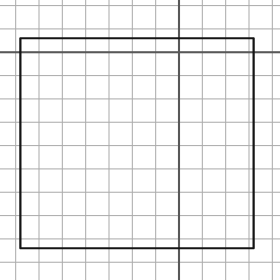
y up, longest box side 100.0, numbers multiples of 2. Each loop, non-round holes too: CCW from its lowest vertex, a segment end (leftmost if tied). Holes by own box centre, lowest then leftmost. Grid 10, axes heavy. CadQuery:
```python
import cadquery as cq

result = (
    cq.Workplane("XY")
    .moveTo(-68.0, -84.0)
    .lineTo(32.0, -84.0)
    .lineTo(32.0, 6.0)
    .lineTo(-68.0, 6.0)
    .close()
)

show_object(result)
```